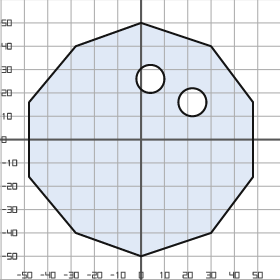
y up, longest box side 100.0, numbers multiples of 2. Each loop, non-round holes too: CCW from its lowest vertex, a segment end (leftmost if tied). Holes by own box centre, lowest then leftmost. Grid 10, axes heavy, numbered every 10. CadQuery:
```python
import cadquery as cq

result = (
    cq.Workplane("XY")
    .moveTo(0.0, -50.0)
    .lineTo(30.0, -40.0)
    .lineTo(48.0, -16.0)
    .lineTo(48.0, 16.0)
    .lineTo(30.0, 40.0)
    .lineTo(0.0, 50.0)
    .lineTo(-28.0, 40.0)
    .lineTo(-48.0, 16.0)
    .lineTo(-48.0, -16.0)
    .lineTo(-28.0, -40.0)
    .close()
    .moveTo(22.0, 16.0)
    .circle(6.0)
    .moveTo(4.0, 26.0)
    .circle(6.0)
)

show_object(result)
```